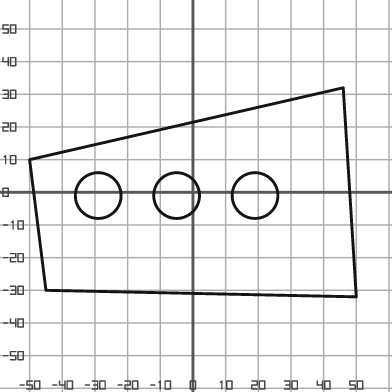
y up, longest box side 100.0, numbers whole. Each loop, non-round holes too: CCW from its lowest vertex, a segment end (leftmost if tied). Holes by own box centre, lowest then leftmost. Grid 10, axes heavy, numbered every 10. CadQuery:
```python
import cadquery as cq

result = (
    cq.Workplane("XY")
    .moveTo(50.0, -32.0)
    .lineTo(46.0, 32.0)
    .lineTo(-50.0, 10.0)
    .lineTo(-45.0, -30.0)
    .close()
    .moveTo(-29.0, -1.0)
    .circle(7.0)
    .moveTo(-5.0, -1.0)
    .circle(7.0)
    .moveTo(19.0, -1.0)
    .circle(7.0)
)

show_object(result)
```